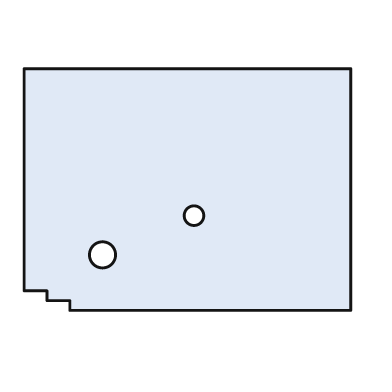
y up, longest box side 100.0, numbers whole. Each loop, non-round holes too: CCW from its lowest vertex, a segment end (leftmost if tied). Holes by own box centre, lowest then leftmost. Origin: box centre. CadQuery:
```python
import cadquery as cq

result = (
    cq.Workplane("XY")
    .moveTo(-36.0, -37.0)
    .lineTo(50.0, -37.0)
    .lineTo(50.0, 37.0)
    .lineTo(-50.0, 37.0)
    .lineTo(-50.0, -31.0)
    .lineTo(-43.0, -31.0)
    .lineTo(-43.0, -34.0)
    .lineTo(-36.0, -34.0)
    .close()
    .moveTo(-26.0, -20.0)
    .circle(4.0)
    .moveTo(2.0, -8.0)
    .circle(3.0)
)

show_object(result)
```